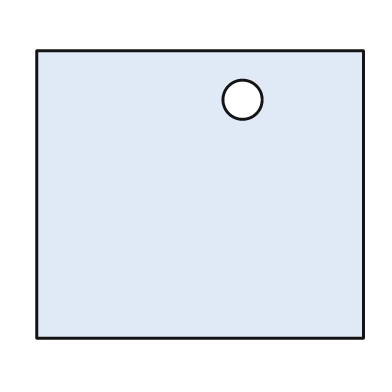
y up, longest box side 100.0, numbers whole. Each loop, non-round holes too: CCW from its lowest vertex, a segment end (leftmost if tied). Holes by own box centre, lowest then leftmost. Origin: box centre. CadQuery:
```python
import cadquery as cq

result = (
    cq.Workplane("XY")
    .moveTo(-50.0, -44.0)
    .lineTo(50.0, -44.0)
    .lineTo(50.0, 44.0)
    .lineTo(-50.0, 44.0)
    .close()
    .moveTo(13.0, 29.0)
    .circle(6.0)
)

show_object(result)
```